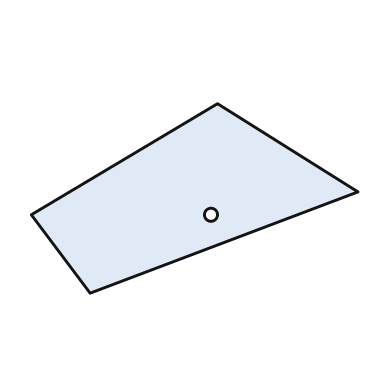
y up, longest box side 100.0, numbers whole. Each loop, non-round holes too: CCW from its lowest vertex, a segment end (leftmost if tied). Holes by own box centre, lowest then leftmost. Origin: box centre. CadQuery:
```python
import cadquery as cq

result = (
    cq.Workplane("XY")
    .moveTo(-32.0, -29.0)
    .lineTo(50.0, 2.0)
    .lineTo(7.0, 29.0)
    .lineTo(-50.0, -5.0)
    .close()
    .moveTo(5.0, -5.0)
    .circle(2.0)
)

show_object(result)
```